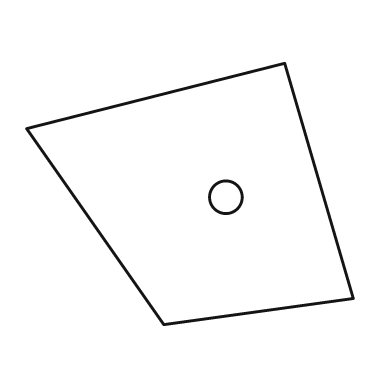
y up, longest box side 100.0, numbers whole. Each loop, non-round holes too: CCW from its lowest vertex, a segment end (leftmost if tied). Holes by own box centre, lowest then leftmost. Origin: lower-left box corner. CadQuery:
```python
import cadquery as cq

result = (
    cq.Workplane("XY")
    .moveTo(42.0, 0.0)
    .lineTo(100.0, 8.0)
    .lineTo(79.0, 80.0)
    .lineTo(0.0, 60.0)
    .close()
    .moveTo(61.0, 39.0)
    .circle(5.0)
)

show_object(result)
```